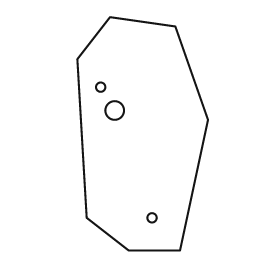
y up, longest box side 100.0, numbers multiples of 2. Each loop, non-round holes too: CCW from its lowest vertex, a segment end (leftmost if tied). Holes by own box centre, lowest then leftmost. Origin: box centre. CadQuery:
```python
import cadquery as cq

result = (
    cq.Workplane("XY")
    .moveTo(-6.0, -50.0)
    .lineTo(16.0, -50.0)
    .lineTo(28.0, 6.0)
    .lineTo(14.0, 46.0)
    .lineTo(-14.0, 50.0)
    .lineTo(-28.0, 32.0)
    .lineTo(-24.0, -36.0)
    .close()
    .moveTo(4.0, -36.0)
    .circle(2.0)
    .moveTo(-12.0, 10.0)
    .circle(4.0)
    .moveTo(-18.0, 20.0)
    .circle(2.0)
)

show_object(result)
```